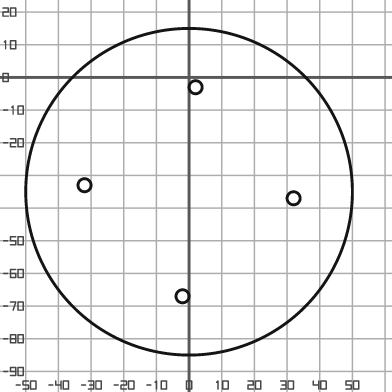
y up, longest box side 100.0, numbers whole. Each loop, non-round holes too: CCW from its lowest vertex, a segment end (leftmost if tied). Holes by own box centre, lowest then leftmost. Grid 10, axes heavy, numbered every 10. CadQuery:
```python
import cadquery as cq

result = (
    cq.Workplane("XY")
    .moveTo(0.0, -35.0)
    .circle(50.0)
    .moveTo(-2.0, -67.0)
    .circle(2.0)
    .moveTo(32.0, -37.0)
    .circle(2.0)
    .moveTo(-32.0, -33.0)
    .circle(2.0)
    .moveTo(2.0, -3.0)
    .circle(2.0)
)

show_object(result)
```